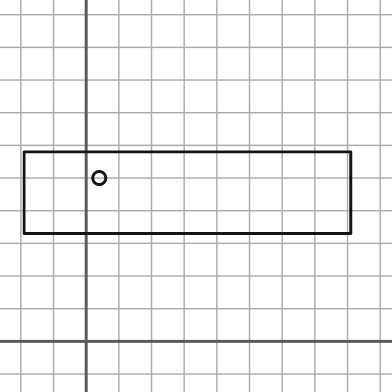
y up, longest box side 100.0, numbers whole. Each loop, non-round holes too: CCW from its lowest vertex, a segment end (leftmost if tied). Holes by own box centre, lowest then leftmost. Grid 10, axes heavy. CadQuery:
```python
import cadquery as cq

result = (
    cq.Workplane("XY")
    .moveTo(-19.0, 33.0)
    .lineTo(81.0, 33.0)
    .lineTo(81.0, 58.0)
    .lineTo(-19.0, 58.0)
    .close()
    .moveTo(4.0, 50.0)
    .circle(2.0)
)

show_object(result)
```